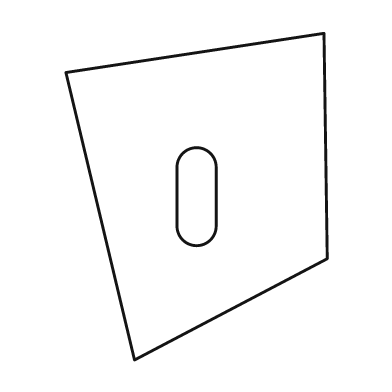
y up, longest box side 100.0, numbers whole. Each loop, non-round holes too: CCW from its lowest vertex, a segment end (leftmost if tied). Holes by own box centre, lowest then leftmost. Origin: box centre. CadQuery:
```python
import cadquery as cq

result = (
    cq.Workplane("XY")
    .moveTo(-19.0, -50.0)
    .lineTo(40.0, -19.0)
    .lineTo(39.0, 50.0)
    .lineTo(-40.0, 38.0)
    .close()
    .moveTo(-6.0, -9.0)
    .threePointArc((0.0, -15.0), (6.0, -9.0))
    .lineTo(6.0, 9.0)
    .threePointArc((0.0, 15.0), (-6.0, 9.0))
    .close()
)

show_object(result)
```